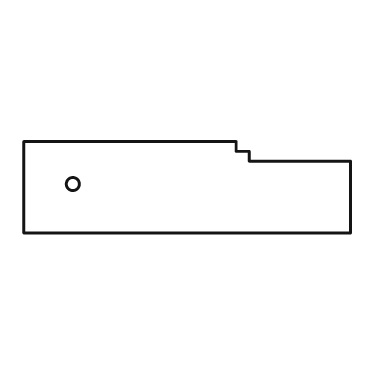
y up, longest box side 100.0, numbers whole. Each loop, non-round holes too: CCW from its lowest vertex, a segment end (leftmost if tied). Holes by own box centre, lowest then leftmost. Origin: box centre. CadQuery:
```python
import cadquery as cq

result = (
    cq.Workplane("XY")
    .moveTo(-50.0, -14.0)
    .lineTo(50.0, -14.0)
    .lineTo(50.0, 8.0)
    .lineTo(19.0, 8.0)
    .lineTo(19.0, 11.0)
    .lineTo(15.0, 11.0)
    .lineTo(15.0, 14.0)
    .lineTo(-50.0, 14.0)
    .close()
    .moveTo(-35.0, 1.0)
    .circle(2.0)
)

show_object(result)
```